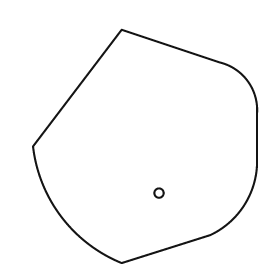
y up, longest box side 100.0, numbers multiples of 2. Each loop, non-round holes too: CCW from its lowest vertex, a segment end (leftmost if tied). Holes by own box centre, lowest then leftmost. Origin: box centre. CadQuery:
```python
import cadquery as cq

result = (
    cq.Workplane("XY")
    .moveTo(-10.0, -50.0)
    .lineTo(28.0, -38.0)
    .threePointArc((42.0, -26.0), (48.0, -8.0))
    .lineTo(48.0, 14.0)
    .threePointArc((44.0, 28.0), (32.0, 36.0))
    .lineTo(-10.0, 50.0)
    .lineTo(-48.0, 0.0)
    .threePointArc((-36.0, -30.0), (-10.0, -50.0))
    .close()
    .moveTo(6.0, -20.0)
    .circle(2.0)
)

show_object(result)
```